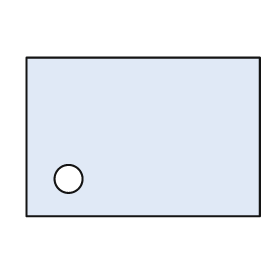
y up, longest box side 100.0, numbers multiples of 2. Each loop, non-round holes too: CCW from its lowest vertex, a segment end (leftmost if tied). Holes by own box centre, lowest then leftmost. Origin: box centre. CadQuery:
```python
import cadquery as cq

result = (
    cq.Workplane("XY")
    .moveTo(-50.0, -34.0)
    .lineTo(50.0, -34.0)
    .lineTo(50.0, 34.0)
    .lineTo(-50.0, 34.0)
    .close()
    .moveTo(-32.0, -18.0)
    .circle(6.0)
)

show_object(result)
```